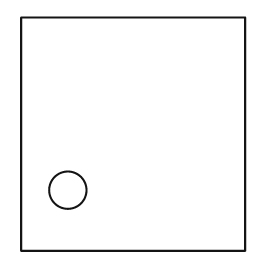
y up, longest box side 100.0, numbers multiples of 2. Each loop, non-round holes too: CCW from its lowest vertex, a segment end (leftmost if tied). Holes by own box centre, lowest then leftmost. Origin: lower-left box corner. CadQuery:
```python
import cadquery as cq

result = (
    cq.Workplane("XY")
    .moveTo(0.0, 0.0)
    .lineTo(96.0, 0.0)
    .lineTo(96.0, 100.0)
    .lineTo(0.0, 100.0)
    .close()
    .moveTo(20.0, 26.0)
    .circle(8.0)
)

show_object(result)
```